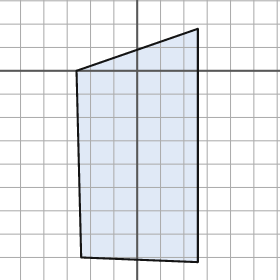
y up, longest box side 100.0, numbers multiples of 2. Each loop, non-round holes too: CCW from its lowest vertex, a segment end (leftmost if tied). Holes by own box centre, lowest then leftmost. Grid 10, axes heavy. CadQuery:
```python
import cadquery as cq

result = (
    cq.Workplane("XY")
    .moveTo(26.0, -82.0)
    .lineTo(26.0, 18.0)
    .lineTo(-26.0, 0.0)
    .lineTo(-24.0, -80.0)
    .close()
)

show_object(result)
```